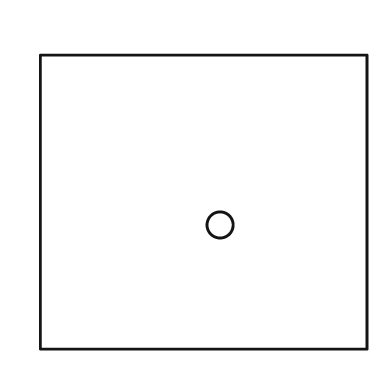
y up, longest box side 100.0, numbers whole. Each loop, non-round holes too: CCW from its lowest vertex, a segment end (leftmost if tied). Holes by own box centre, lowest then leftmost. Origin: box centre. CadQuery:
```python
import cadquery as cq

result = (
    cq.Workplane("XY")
    .moveTo(-50.0, -45.0)
    .lineTo(50.0, -45.0)
    .lineTo(50.0, 45.0)
    .lineTo(-50.0, 45.0)
    .close()
    .moveTo(5.0, -7.0)
    .circle(4.0)
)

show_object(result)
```